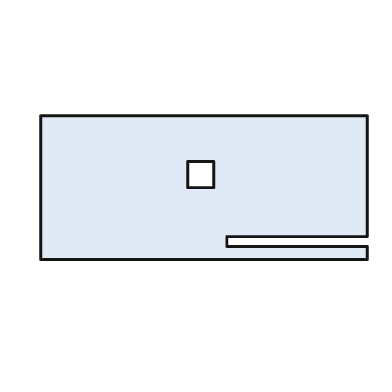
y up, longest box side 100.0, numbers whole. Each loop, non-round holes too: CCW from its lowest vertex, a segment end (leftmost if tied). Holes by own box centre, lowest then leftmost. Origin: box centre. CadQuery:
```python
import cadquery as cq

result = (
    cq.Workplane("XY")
    .moveTo(-50.0, -22.0)
    .lineTo(50.0, -22.0)
    .lineTo(50.0, -18.0)
    .lineTo(7.0, -18.0)
    .lineTo(7.0, -15.0)
    .lineTo(50.0, -15.0)
    .lineTo(50.0, 22.0)
    .lineTo(-50.0, 22.0)
    .close()
    .moveTo(-5.0, 0.0)
    .lineTo(3.0, 0.0)
    .lineTo(3.0, 8.0)
    .lineTo(-5.0, 8.0)
    .close()
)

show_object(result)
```